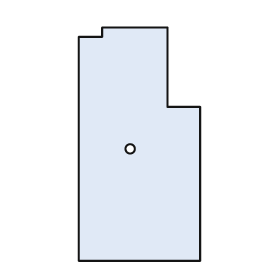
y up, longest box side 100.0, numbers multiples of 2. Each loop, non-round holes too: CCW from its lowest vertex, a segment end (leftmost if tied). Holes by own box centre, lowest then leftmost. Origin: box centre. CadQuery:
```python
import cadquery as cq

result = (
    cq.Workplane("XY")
    .moveTo(-26.0, -50.0)
    .lineTo(26.0, -50.0)
    .lineTo(26.0, 16.0)
    .lineTo(12.0, 16.0)
    .lineTo(12.0, 50.0)
    .lineTo(-16.0, 50.0)
    .lineTo(-16.0, 46.0)
    .lineTo(-26.0, 46.0)
    .close()
    .moveTo(-4.0, -2.0)
    .circle(2.0)
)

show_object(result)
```